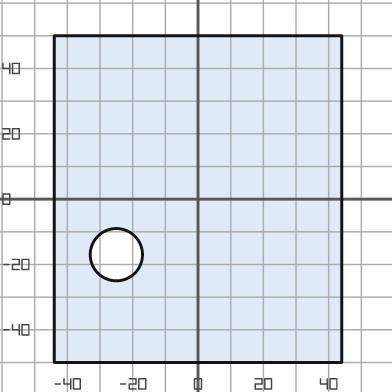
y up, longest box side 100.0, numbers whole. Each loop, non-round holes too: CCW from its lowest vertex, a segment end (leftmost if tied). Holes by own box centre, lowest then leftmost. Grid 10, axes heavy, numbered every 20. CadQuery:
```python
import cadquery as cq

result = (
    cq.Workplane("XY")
    .moveTo(-44.0, -50.0)
    .lineTo(44.0, -50.0)
    .lineTo(44.0, 50.0)
    .lineTo(-44.0, 50.0)
    .close()
    .moveTo(-25.0, -17.0)
    .circle(8.0)
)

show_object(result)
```